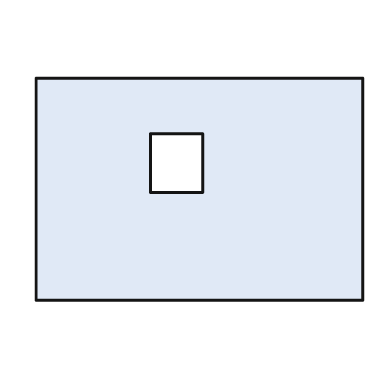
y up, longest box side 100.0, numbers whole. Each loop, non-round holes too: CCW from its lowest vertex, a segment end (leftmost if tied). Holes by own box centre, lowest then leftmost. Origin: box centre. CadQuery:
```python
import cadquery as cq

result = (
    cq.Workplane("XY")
    .moveTo(-50.0, -34.0)
    .lineTo(50.0, -34.0)
    .lineTo(50.0, 34.0)
    .lineTo(-50.0, 34.0)
    .close()
    .moveTo(-15.0, -1.0)
    .lineTo(1.0, -1.0)
    .lineTo(1.0, 17.0)
    .lineTo(-15.0, 17.0)
    .close()
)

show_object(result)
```